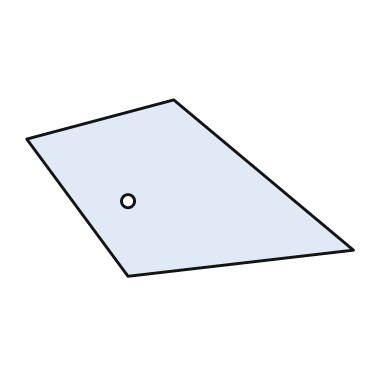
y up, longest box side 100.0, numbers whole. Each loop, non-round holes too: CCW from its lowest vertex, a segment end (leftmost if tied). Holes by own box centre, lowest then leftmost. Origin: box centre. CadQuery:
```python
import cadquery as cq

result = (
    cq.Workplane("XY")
    .moveTo(-19.0, -27.0)
    .lineTo(50.0, -19.0)
    .lineTo(-5.0, 27.0)
    .lineTo(-50.0, 15.0)
    .close()
    .moveTo(-19.0, -4.0)
    .circle(2.0)
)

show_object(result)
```